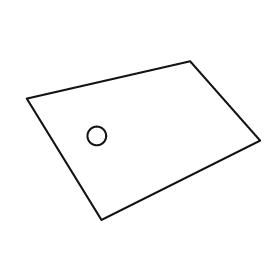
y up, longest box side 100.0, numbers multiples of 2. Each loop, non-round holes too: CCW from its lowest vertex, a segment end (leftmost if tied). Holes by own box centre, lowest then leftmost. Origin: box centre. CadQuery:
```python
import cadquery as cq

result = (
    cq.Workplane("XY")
    .moveTo(-18.0, -34.0)
    .lineTo(50.0, 0.0)
    .lineTo(20.0, 34.0)
    .lineTo(-50.0, 18.0)
    .close()
    .moveTo(-20.0, 2.0)
    .circle(4.0)
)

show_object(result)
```